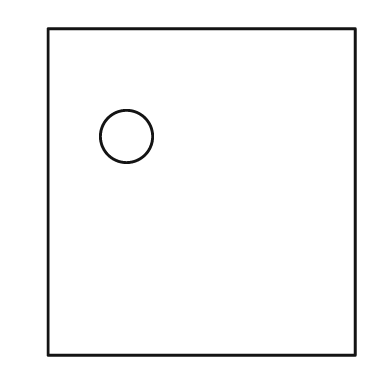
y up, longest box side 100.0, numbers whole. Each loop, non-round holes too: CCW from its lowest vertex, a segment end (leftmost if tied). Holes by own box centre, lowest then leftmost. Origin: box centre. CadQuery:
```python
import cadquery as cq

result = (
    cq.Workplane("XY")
    .moveTo(-47.0, -50.0)
    .lineTo(47.0, -50.0)
    .lineTo(47.0, 50.0)
    .lineTo(-47.0, 50.0)
    .close()
    .moveTo(-23.0, 17.0)
    .circle(8.0)
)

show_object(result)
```